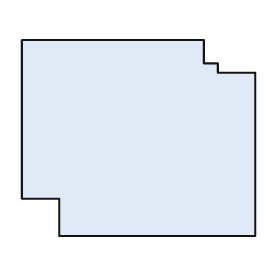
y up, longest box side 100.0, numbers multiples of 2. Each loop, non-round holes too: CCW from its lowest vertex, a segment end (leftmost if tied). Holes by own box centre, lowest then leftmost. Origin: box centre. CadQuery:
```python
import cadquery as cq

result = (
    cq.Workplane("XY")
    .moveTo(-34.0, -42.0)
    .lineTo(50.0, -42.0)
    .lineTo(50.0, 28.0)
    .lineTo(34.0, 28.0)
    .lineTo(34.0, 32.0)
    .lineTo(28.0, 32.0)
    .lineTo(28.0, 42.0)
    .lineTo(-50.0, 42.0)
    .lineTo(-50.0, -26.0)
    .lineTo(-34.0, -26.0)
    .close()
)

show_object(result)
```